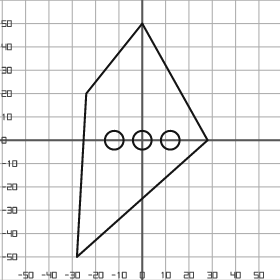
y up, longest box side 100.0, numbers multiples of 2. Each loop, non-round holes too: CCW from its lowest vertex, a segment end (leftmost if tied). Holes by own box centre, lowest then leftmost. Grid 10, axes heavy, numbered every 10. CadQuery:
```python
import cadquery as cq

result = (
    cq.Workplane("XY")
    .moveTo(-28.0, -50.0)
    .lineTo(28.0, 0.0)
    .lineTo(0.0, 50.0)
    .lineTo(-24.0, 20.0)
    .close()
    .moveTo(-12.0, 0.0)
    .circle(4.0)
    .moveTo(0.0, 0.0)
    .circle(4.0)
    .moveTo(12.0, 0.0)
    .circle(4.0)
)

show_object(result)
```